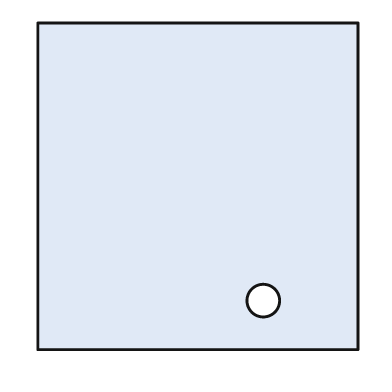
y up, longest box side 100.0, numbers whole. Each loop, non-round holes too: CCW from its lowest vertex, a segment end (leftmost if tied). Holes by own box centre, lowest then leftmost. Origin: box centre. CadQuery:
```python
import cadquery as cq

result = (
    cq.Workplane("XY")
    .moveTo(-49.0, -50.0)
    .lineTo(49.0, -50.0)
    .lineTo(49.0, 50.0)
    .lineTo(-49.0, 50.0)
    .close()
    .moveTo(20.0, -35.0)
    .circle(5.0)
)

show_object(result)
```